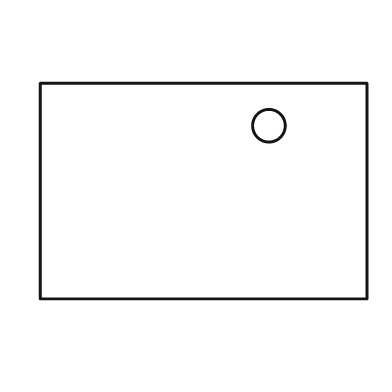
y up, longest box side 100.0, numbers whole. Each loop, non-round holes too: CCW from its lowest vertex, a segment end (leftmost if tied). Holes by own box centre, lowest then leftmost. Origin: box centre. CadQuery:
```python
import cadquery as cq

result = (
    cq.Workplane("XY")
    .moveTo(-50.0, -33.0)
    .lineTo(50.0, -33.0)
    .lineTo(50.0, 33.0)
    .lineTo(-50.0, 33.0)
    .close()
    .moveTo(20.0, 20.0)
    .circle(5.0)
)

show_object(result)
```